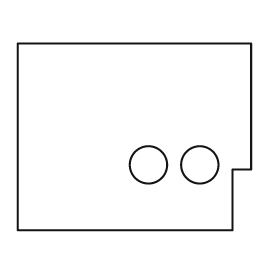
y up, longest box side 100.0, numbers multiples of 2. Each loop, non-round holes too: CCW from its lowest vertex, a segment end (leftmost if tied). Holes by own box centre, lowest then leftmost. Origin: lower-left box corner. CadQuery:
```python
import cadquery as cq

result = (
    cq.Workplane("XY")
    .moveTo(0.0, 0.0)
    .lineTo(92.0, 0.0)
    .lineTo(92.0, 26.0)
    .lineTo(100.0, 26.0)
    .lineTo(100.0, 80.0)
    .lineTo(0.0, 80.0)
    .close()
    .moveTo(56.0, 28.0)
    .circle(8.0)
    .moveTo(78.0, 28.0)
    .circle(8.0)
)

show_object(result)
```